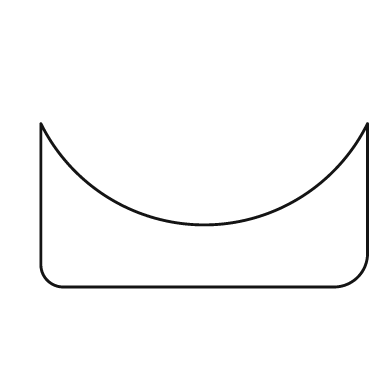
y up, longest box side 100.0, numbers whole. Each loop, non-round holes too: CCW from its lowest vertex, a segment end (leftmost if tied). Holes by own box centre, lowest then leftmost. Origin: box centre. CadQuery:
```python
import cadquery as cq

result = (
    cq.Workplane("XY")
    .moveTo(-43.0, -25.0)
    .lineTo(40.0, -25.0)
    .threePointArc((47.0, -22.0), (50.0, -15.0))
    .lineTo(50.0, 25.0)
    .threePointArc((0.0, -6.0), (-50.0, 25.0))
    .lineTo(-50.0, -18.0)
    .threePointArc((-48.0, -23.0), (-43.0, -25.0))
    .close()
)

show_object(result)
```